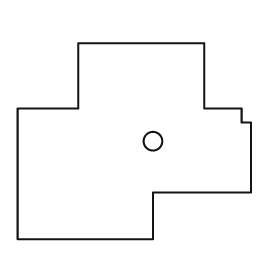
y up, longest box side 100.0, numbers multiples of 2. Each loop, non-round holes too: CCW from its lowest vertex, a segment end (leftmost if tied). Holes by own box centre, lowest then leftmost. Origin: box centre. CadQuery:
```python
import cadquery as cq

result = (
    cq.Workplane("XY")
    .moveTo(-50.0, -42.0)
    .lineTo(8.0, -42.0)
    .lineTo(8.0, -22.0)
    .lineTo(50.0, -22.0)
    .lineTo(50.0, 8.0)
    .lineTo(46.0, 8.0)
    .lineTo(46.0, 14.0)
    .lineTo(30.0, 14.0)
    .lineTo(30.0, 42.0)
    .lineTo(-24.0, 42.0)
    .lineTo(-24.0, 14.0)
    .lineTo(-50.0, 14.0)
    .close()
    .moveTo(8.0, 0.0)
    .circle(4.0)
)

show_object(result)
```